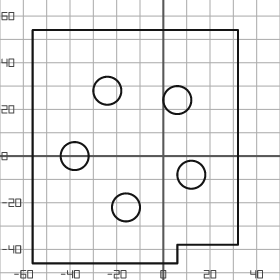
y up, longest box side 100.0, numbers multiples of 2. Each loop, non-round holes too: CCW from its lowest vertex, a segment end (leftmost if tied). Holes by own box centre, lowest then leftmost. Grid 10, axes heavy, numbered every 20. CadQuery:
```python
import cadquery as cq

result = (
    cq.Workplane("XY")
    .moveTo(-56.0, -46.0)
    .lineTo(6.0, -46.0)
    .lineTo(6.0, -38.0)
    .lineTo(32.0, -38.0)
    .lineTo(32.0, 54.0)
    .lineTo(-56.0, 54.0)
    .close()
    .moveTo(-16.0, -22.0)
    .circle(6.0)
    .moveTo(12.0, -8.0)
    .circle(6.0)
    .moveTo(-38.0, 0.0)
    .circle(6.0)
    .moveTo(6.0, 24.0)
    .circle(6.0)
    .moveTo(-24.0, 28.0)
    .circle(6.0)
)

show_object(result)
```